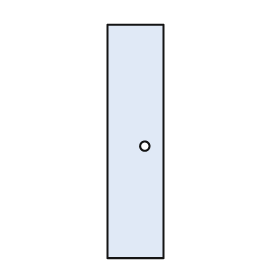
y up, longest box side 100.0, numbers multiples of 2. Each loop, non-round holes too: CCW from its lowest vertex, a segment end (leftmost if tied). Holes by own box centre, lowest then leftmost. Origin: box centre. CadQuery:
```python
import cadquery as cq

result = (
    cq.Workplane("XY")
    .moveTo(-12.0, -50.0)
    .lineTo(12.0, -50.0)
    .lineTo(12.0, 50.0)
    .lineTo(-12.0, 50.0)
    .close()
    .moveTo(4.0, -2.0)
    .circle(2.0)
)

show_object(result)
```